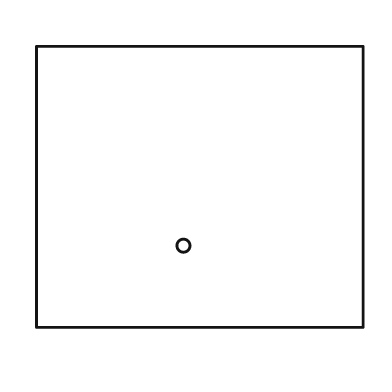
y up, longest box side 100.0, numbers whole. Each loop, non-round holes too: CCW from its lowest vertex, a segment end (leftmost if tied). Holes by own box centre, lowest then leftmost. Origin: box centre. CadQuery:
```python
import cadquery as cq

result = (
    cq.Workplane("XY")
    .moveTo(-50.0, -43.0)
    .lineTo(50.0, -43.0)
    .lineTo(50.0, 43.0)
    .lineTo(-50.0, 43.0)
    .close()
    .moveTo(-5.0, -18.0)
    .circle(2.0)
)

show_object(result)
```